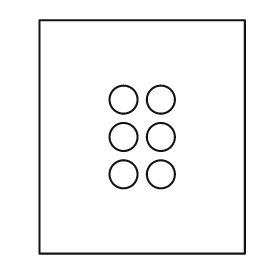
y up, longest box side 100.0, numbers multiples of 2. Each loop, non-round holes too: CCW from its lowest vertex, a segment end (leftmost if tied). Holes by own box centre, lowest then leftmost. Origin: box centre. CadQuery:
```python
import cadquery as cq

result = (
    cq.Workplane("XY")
    .moveTo(-44.0, -50.0)
    .lineTo(44.0, -50.0)
    .lineTo(44.0, 50.0)
    .lineTo(-44.0, 50.0)
    .close()
    .moveTo(-8.0, -16.0)
    .circle(6.0)
    .moveTo(8.0, -16.0)
    .circle(6.0)
    .moveTo(-8.0, 0.0)
    .circle(6.0)
    .moveTo(8.0, 0.0)
    .circle(6.0)
    .moveTo(-8.0, 16.0)
    .circle(6.0)
    .moveTo(8.0, 16.0)
    .circle(6.0)
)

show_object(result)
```